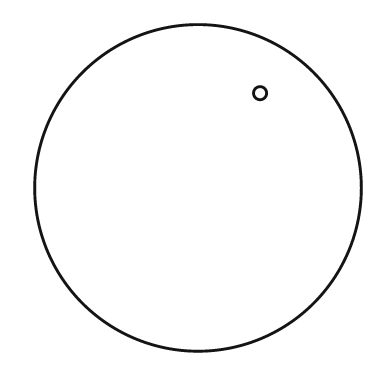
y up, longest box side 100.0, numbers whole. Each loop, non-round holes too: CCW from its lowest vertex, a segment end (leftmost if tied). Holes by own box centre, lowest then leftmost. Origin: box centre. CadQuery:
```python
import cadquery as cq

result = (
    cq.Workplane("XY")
    .moveTo(0.0, 0.0)
    .circle(50.0)
    .moveTo(19.0, 29.0)
    .circle(2.0)
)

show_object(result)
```